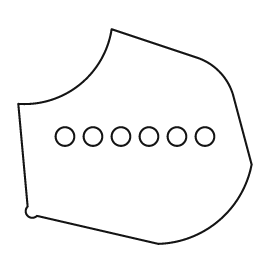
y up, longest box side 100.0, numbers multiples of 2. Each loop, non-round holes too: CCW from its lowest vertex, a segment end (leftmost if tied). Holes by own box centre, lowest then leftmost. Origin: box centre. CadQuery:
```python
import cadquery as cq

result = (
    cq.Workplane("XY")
    .moveTo(10.0, -46.0)
    .threePointArc((36.0, -36.0), (50.0, -12.0))
    .lineTo(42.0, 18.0)
    .threePointArc((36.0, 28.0), (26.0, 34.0))
    .lineTo(-10.0, 46.0)
    .threePointArc((-24.0, 22.0), (-50.0, 14.0))
    .lineTo(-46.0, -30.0)
    .threePointArc((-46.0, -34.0), (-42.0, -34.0))
    .close()
    .moveTo(-30.0, 0.0)
    .circle(4.0)
    .moveTo(-18.0, 0.0)
    .circle(4.0)
    .moveTo(-6.0, 0.0)
    .circle(4.0)
    .moveTo(6.0, 0.0)
    .circle(4.0)
    .moveTo(18.0, 0.0)
    .circle(4.0)
    .moveTo(30.0, 0.0)
    .circle(4.0)
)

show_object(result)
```